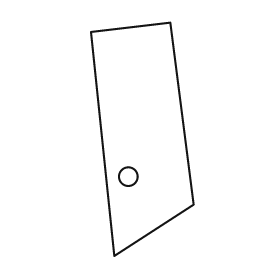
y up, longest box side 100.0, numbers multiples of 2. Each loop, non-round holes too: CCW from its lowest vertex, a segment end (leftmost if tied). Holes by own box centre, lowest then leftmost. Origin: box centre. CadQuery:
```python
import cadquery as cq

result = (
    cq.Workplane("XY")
    .moveTo(-12.0, -50.0)
    .lineTo(22.0, -28.0)
    .lineTo(12.0, 50.0)
    .lineTo(-22.0, 46.0)
    .close()
    .moveTo(-6.0, -16.0)
    .circle(4.0)
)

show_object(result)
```